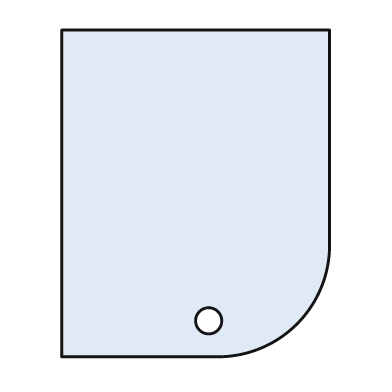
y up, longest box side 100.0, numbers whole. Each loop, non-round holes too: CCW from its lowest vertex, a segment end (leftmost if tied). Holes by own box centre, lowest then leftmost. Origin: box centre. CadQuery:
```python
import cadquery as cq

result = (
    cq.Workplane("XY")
    .moveTo(-41.0, -50.0)
    .lineTo(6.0, -50.0)
    .threePointArc((31.0, -40.0), (41.0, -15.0))
    .lineTo(41.0, 50.0)
    .lineTo(-41.0, 50.0)
    .close()
    .moveTo(4.0, -39.0)
    .circle(4.0)
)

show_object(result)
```